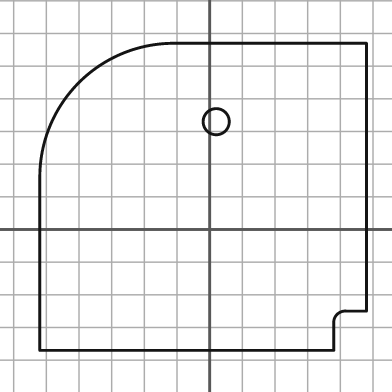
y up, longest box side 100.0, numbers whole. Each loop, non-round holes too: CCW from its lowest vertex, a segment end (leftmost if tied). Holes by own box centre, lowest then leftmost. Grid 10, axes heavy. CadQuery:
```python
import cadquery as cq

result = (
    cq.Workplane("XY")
    .moveTo(-52.0, -37.0)
    .lineTo(38.0, -37.0)
    .lineTo(38.0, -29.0)
    .threePointArc((39.0, -26.0), (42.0, -25.0))
    .lineTo(48.0, -25.0)
    .lineTo(48.0, 57.0)
    .lineTo(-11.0, 57.0)
    .threePointArc((-40.0, 45.0), (-52.0, 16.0))
    .close()
    .moveTo(2.0, 33.0)
    .circle(4.0)
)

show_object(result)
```